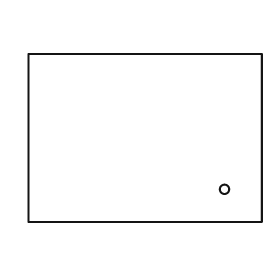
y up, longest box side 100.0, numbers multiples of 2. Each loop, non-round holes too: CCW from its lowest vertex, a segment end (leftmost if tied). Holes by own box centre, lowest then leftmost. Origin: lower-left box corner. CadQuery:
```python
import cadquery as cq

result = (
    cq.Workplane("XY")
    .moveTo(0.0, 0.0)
    .lineTo(100.0, 0.0)
    .lineTo(100.0, 72.0)
    .lineTo(0.0, 72.0)
    .close()
    .moveTo(84.0, 14.0)
    .circle(2.0)
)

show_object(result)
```